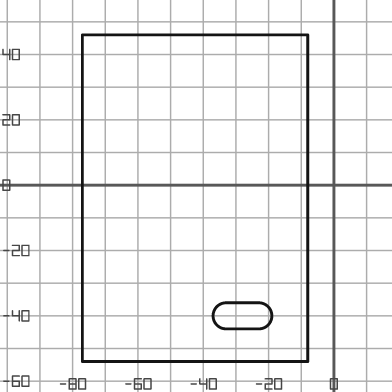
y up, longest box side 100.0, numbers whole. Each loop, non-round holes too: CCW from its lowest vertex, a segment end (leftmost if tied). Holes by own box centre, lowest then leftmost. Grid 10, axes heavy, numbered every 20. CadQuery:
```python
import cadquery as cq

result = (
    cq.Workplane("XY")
    .moveTo(-77.0, -54.0)
    .lineTo(-8.0, -54.0)
    .lineTo(-8.0, 46.0)
    .lineTo(-77.0, 46.0)
    .close()
    .moveTo(-33.0, -44.0)
    .lineTo(-23.0, -44.0)
    .threePointArc((-19.0, -40.0), (-23.0, -36.0))
    .lineTo(-33.0, -36.0)
    .threePointArc((-37.0, -40.0), (-33.0, -44.0))
    .close()
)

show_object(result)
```